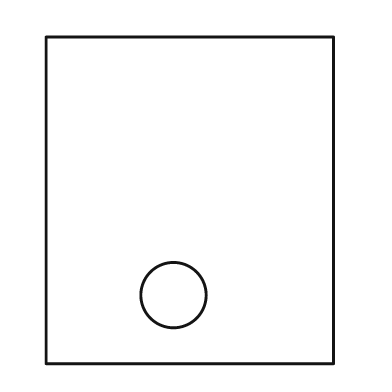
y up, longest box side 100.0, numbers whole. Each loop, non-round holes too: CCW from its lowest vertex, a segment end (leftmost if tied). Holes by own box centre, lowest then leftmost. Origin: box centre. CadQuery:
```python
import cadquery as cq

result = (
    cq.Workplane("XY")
    .moveTo(-44.0, -50.0)
    .lineTo(44.0, -50.0)
    .lineTo(44.0, 50.0)
    .lineTo(-44.0, 50.0)
    .close()
    .moveTo(-5.0, -29.0)
    .circle(10.0)
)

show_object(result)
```